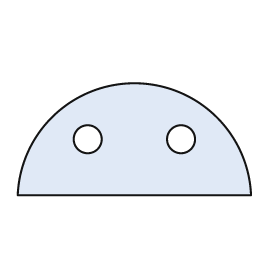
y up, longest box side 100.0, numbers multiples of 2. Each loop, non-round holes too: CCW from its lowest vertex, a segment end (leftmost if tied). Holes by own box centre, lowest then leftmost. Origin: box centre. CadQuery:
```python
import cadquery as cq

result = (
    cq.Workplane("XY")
    .moveTo(-50.0, -24.0)
    .lineTo(50.0, -24.0)
    .threePointArc((0.0, 24.0), (-50.0, -24.0))
    .close()
    .moveTo(-20.0, 0.0)
    .circle(6.0)
    .moveTo(20.0, 0.0)
    .circle(6.0)
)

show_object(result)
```